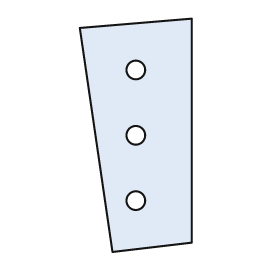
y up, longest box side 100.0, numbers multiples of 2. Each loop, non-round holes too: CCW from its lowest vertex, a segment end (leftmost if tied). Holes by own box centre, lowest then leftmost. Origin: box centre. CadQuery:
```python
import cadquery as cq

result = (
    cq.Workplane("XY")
    .moveTo(-10.0, -50.0)
    .lineTo(24.0, -46.0)
    .lineTo(24.0, 50.0)
    .lineTo(-24.0, 46.0)
    .close()
    .moveTo(0.0, -28.0)
    .circle(4.0)
    .moveTo(0.0, 0.0)
    .circle(4.0)
    .moveTo(0.0, 28.0)
    .circle(4.0)
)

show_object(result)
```